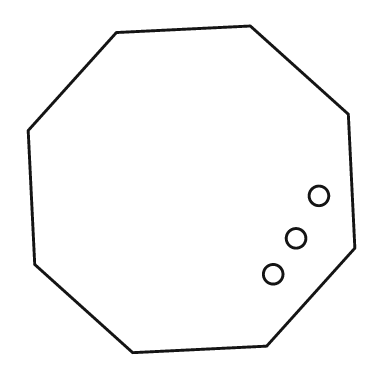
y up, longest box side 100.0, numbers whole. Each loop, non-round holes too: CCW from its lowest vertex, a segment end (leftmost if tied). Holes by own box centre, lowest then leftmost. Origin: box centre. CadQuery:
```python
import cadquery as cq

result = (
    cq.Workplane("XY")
    .moveTo(-18.0, -50.0)
    .lineTo(23.0, -48.0)
    .lineTo(50.0, -18.0)
    .lineTo(48.0, 23.0)
    .lineTo(18.0, 50.0)
    .lineTo(-23.0, 48.0)
    .lineTo(-50.0, 18.0)
    .lineTo(-48.0, -23.0)
    .close()
    .moveTo(25.0, -26.0)
    .circle(3.0)
    .moveTo(32.0, -15.0)
    .circle(3.0)
    .moveTo(39.0, -2.0)
    .circle(3.0)
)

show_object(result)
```